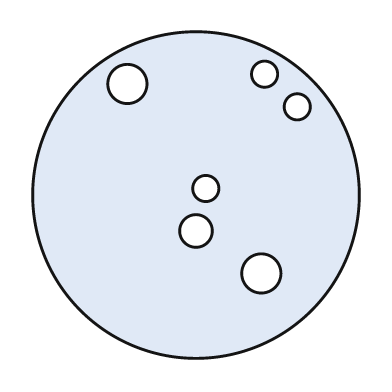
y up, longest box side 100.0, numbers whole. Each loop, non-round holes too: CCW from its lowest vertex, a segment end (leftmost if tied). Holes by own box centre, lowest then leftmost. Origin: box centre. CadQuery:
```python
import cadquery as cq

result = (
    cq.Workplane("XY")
    .moveTo(0.0, 0.0)
    .circle(50.0)
    .moveTo(20.0, -24.0)
    .circle(6.0)
    .moveTo(0.0, -11.0)
    .circle(5.0)
    .moveTo(3.0, 2.0)
    .circle(4.0)
    .moveTo(31.0, 27.0)
    .circle(4.0)
    .moveTo(-21.0, 34.0)
    .circle(6.0)
    .moveTo(21.0, 37.0)
    .circle(4.0)
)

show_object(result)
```